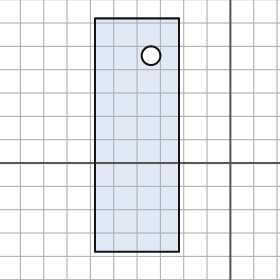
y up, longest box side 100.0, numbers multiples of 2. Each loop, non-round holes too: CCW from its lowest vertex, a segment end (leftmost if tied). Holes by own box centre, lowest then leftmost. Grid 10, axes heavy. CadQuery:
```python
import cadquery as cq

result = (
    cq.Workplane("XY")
    .moveTo(-58.0, -38.0)
    .lineTo(-22.0, -38.0)
    .lineTo(-22.0, 62.0)
    .lineTo(-58.0, 62.0)
    .close()
    .moveTo(-34.0, 46.0)
    .circle(4.0)
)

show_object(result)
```